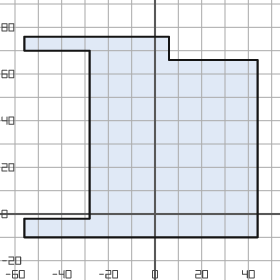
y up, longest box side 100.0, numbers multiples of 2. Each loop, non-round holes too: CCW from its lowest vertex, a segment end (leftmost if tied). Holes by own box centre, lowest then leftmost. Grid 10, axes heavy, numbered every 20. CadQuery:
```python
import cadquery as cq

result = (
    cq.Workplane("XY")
    .moveTo(-56.0, -10.0)
    .lineTo(44.0, -10.0)
    .lineTo(44.0, 66.0)
    .lineTo(6.0, 66.0)
    .lineTo(6.0, 76.0)
    .lineTo(-56.0, 76.0)
    .lineTo(-56.0, 70.0)
    .lineTo(-28.0, 70.0)
    .lineTo(-28.0, -2.0)
    .lineTo(-56.0, -2.0)
    .close()
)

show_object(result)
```